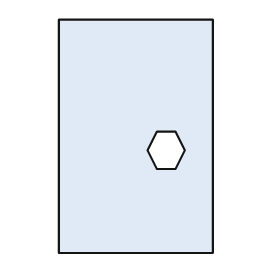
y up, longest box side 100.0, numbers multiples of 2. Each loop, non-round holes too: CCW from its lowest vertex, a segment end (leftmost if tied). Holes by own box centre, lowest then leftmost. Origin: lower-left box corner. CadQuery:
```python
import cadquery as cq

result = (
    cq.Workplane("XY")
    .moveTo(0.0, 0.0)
    .lineTo(66.0, 0.0)
    .lineTo(66.0, 100.0)
    .lineTo(0.0, 100.0)
    .close()
    .moveTo(42.0, 36.0)
    .lineTo(50.0, 36.0)
    .lineTo(54.0, 44.0)
    .lineTo(50.0, 52.0)
    .lineTo(42.0, 52.0)
    .lineTo(38.0, 44.0)
    .close()
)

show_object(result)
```